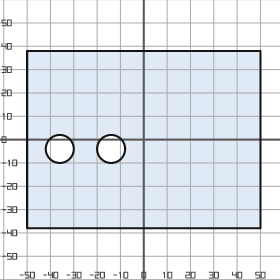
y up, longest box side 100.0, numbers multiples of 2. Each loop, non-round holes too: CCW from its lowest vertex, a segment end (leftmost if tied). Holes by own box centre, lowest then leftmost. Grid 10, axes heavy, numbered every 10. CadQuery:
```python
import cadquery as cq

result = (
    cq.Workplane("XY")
    .moveTo(-50.0, -38.0)
    .lineTo(50.0, -38.0)
    .lineTo(50.0, 38.0)
    .lineTo(-50.0, 38.0)
    .close()
    .moveTo(-36.0, -4.0)
    .circle(6.0)
    .moveTo(-14.0, -4.0)
    .circle(6.0)
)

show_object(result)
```